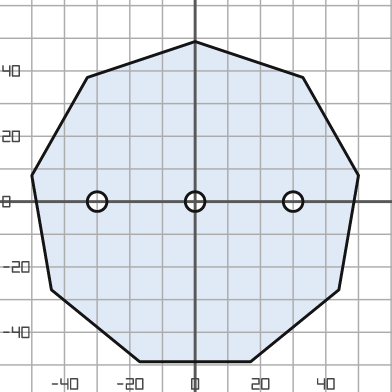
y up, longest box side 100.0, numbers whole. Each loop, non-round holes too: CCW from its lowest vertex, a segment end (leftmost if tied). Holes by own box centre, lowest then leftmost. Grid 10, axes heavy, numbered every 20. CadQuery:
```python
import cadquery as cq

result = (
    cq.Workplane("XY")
    .moveTo(-17.0, -49.0)
    .lineTo(17.0, -49.0)
    .lineTo(44.0, -27.0)
    .lineTo(50.0, 8.0)
    .lineTo(33.0, 38.0)
    .lineTo(0.0, 49.0)
    .lineTo(-33.0, 38.0)
    .lineTo(-50.0, 8.0)
    .lineTo(-44.0, -27.0)
    .close()
    .moveTo(-30.0, 0.0)
    .circle(3.0)
    .moveTo(0.0, 0.0)
    .circle(3.0)
    .moveTo(30.0, 0.0)
    .circle(3.0)
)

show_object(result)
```